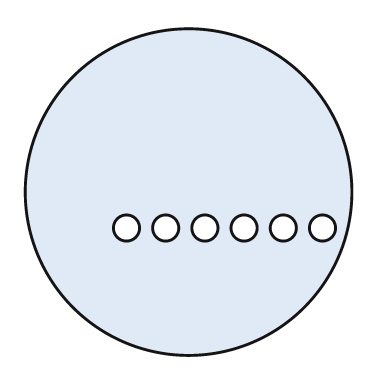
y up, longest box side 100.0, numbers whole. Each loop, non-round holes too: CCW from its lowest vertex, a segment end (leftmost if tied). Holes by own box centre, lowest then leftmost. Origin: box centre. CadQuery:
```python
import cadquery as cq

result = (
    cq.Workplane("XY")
    .moveTo(0.0, 0.0)
    .circle(50.0)
    .moveTo(-19.0, -11.0)
    .circle(4.0)
    .moveTo(-7.0, -11.0)
    .circle(4.0)
    .moveTo(5.0, -11.0)
    .circle(4.0)
    .moveTo(17.0, -11.0)
    .circle(4.0)
    .moveTo(29.0, -11.0)
    .circle(4.0)
    .moveTo(41.0, -11.0)
    .circle(4.0)
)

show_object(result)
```